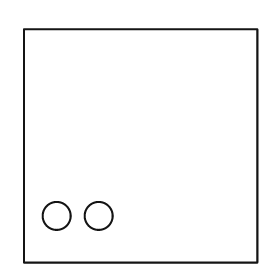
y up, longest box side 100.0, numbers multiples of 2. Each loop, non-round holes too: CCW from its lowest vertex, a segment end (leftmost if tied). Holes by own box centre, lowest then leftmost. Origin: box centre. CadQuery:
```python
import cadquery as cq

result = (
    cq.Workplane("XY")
    .moveTo(-50.0, -50.0)
    .lineTo(50.0, -50.0)
    .lineTo(50.0, 50.0)
    .lineTo(-50.0, 50.0)
    .close()
    .moveTo(-36.0, -30.0)
    .circle(6.0)
    .moveTo(-18.0, -30.0)
    .circle(6.0)
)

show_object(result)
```